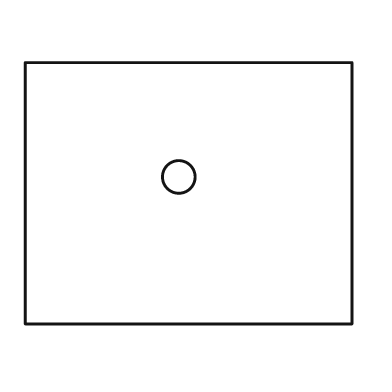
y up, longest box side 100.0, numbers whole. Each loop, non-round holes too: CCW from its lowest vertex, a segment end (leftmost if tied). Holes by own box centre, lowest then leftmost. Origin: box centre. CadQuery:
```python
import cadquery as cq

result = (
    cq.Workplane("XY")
    .moveTo(-50.0, -40.0)
    .lineTo(50.0, -40.0)
    .lineTo(50.0, 40.0)
    .lineTo(-50.0, 40.0)
    .close()
    .moveTo(-3.0, 5.0)
    .circle(5.0)
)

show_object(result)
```